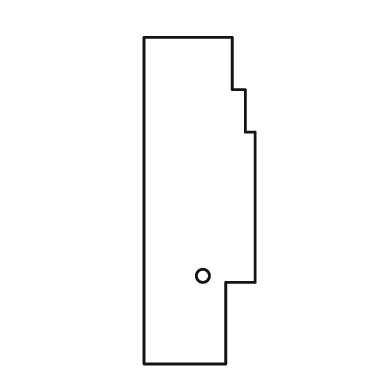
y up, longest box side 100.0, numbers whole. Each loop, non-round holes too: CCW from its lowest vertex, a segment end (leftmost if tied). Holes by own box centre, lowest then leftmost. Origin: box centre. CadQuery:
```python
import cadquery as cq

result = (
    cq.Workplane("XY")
    .moveTo(-17.0, -50.0)
    .lineTo(8.0, -50.0)
    .lineTo(8.0, -25.0)
    .lineTo(17.0, -25.0)
    .lineTo(17.0, 21.0)
    .lineTo(14.0, 21.0)
    .lineTo(14.0, 34.0)
    .lineTo(10.0, 34.0)
    .lineTo(10.0, 50.0)
    .lineTo(-17.0, 50.0)
    .close()
    .moveTo(1.0, -23.0)
    .circle(2.0)
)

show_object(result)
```